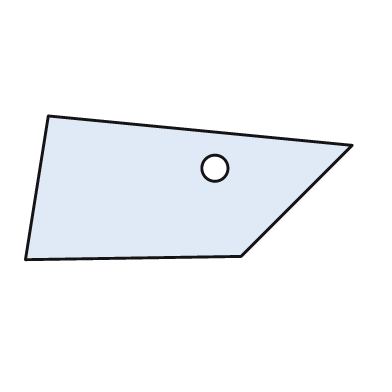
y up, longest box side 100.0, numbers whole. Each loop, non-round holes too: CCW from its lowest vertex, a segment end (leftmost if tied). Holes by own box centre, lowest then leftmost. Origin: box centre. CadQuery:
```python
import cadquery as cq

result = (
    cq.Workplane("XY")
    .moveTo(-50.0, -22.0)
    .lineTo(16.0, -21.0)
    .lineTo(50.0, 13.0)
    .lineTo(-43.0, 22.0)
    .close()
    .moveTo(8.0, 6.0)
    .circle(4.0)
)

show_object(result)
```